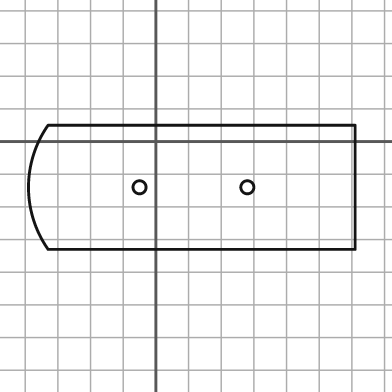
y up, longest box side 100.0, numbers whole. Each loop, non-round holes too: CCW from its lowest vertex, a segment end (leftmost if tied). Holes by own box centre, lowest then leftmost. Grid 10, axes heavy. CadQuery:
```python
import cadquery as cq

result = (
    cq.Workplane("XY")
    .moveTo(-33.0, -33.0)
    .lineTo(61.0, -33.0)
    .lineTo(61.0, 5.0)
    .lineTo(-33.0, 5.0)
    .threePointArc((-39.0, -14.0), (-33.0, -33.0))
    .close()
    .moveTo(-5.0, -14.0)
    .circle(2.0)
    .moveTo(28.0, -14.0)
    .circle(2.0)
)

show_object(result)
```